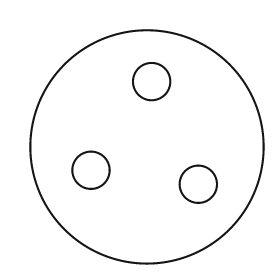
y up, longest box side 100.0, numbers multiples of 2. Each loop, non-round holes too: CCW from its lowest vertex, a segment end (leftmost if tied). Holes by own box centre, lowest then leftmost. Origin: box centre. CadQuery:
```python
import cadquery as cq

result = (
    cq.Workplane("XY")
    .moveTo(0.0, 0.0)
    .circle(50.0)
    .moveTo(22.0, -16.0)
    .circle(8.0)
    .moveTo(-24.0, -10.0)
    .circle(8.0)
    .moveTo(2.0, 28.0)
    .circle(8.0)
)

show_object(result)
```